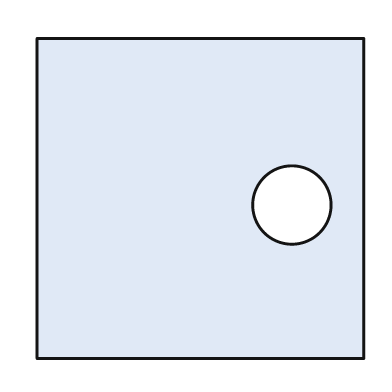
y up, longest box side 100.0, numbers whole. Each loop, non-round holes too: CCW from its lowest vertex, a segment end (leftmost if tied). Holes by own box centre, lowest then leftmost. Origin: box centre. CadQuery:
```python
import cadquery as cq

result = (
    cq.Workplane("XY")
    .moveTo(-50.0, -49.0)
    .lineTo(50.0, -49.0)
    .lineTo(50.0, 49.0)
    .lineTo(-50.0, 49.0)
    .close()
    .moveTo(28.0, -2.0)
    .circle(12.0)
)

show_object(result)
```